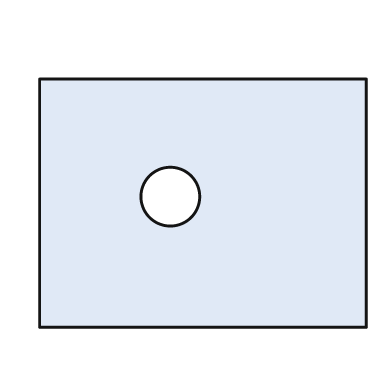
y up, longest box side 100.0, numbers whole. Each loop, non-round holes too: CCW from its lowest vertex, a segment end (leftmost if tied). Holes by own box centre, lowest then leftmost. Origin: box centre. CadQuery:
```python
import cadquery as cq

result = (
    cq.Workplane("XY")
    .moveTo(-50.0, -38.0)
    .lineTo(50.0, -38.0)
    .lineTo(50.0, 38.0)
    .lineTo(-50.0, 38.0)
    .close()
    .moveTo(-10.0, 2.0)
    .circle(9.0)
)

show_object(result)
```